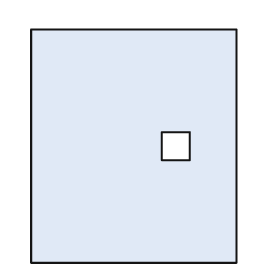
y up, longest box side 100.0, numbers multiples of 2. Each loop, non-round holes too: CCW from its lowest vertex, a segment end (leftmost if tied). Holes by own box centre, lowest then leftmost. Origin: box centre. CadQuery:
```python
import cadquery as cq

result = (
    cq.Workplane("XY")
    .moveTo(-44.0, -50.0)
    .lineTo(44.0, -50.0)
    .lineTo(44.0, 50.0)
    .lineTo(-44.0, 50.0)
    .close()
    .moveTo(12.0, -6.0)
    .lineTo(24.0, -6.0)
    .lineTo(24.0, 6.0)
    .lineTo(12.0, 6.0)
    .close()
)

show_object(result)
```